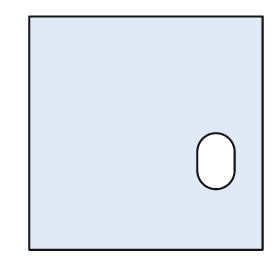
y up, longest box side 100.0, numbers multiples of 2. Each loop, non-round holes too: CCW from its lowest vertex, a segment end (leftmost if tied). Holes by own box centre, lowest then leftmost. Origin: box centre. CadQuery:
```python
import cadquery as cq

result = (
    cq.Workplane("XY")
    .moveTo(-50.0, -50.0)
    .lineTo(50.0, -50.0)
    .lineTo(50.0, 50.0)
    .lineTo(-50.0, 50.0)
    .close()
    .moveTo(22.0, -16.0)
    .threePointArc((30.0, -24.0), (38.0, -16.0))
    .lineTo(38.0, -8.0)
    .threePointArc((30.0, 0.0), (22.0, -8.0))
    .close()
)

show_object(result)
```